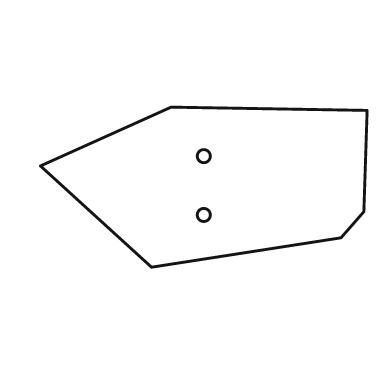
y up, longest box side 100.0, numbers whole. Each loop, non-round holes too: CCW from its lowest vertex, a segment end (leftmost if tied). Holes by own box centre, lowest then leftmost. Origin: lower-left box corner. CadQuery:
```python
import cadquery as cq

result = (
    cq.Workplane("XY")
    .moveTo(34.0, 0.0)
    .lineTo(92.0, 9.0)
    .lineTo(99.0, 17.0)
    .lineTo(100.0, 48.0)
    .lineTo(40.0, 49.0)
    .lineTo(0.0, 31.0)
    .close()
    .moveTo(50.0, 16.0)
    .circle(2.0)
    .moveTo(50.0, 34.0)
    .circle(2.0)
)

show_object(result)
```